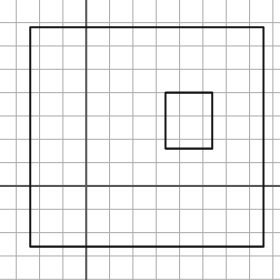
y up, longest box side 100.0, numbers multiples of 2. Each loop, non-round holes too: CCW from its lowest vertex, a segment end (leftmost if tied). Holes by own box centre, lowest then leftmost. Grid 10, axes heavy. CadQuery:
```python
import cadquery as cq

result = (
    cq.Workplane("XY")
    .moveTo(-24.0, -26.0)
    .lineTo(76.0, -26.0)
    .lineTo(76.0, 68.0)
    .lineTo(-24.0, 68.0)
    .close()
    .moveTo(34.0, 16.0)
    .lineTo(54.0, 16.0)
    .lineTo(54.0, 40.0)
    .lineTo(34.0, 40.0)
    .close()
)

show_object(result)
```